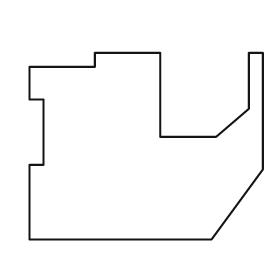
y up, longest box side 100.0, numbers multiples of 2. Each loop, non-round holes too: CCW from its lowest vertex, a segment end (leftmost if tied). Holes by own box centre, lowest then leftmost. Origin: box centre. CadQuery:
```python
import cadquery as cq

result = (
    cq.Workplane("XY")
    .moveTo(-50.0, -40.0)
    .lineTo(28.0, -40.0)
    .lineTo(50.0, -10.0)
    .lineTo(50.0, 40.0)
    .lineTo(44.0, 40.0)
    .lineTo(44.0, 16.0)
    .lineTo(30.0, 4.0)
    .lineTo(6.0, 4.0)
    .lineTo(6.0, 40.0)
    .lineTo(-22.0, 40.0)
    .lineTo(-22.0, 34.0)
    .lineTo(-50.0, 34.0)
    .lineTo(-50.0, 20.0)
    .lineTo(-44.0, 20.0)
    .lineTo(-44.0, -8.0)
    .lineTo(-50.0, -8.0)
    .close()
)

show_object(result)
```